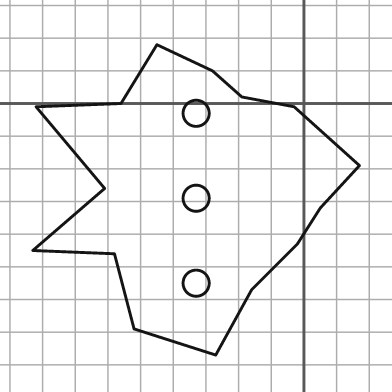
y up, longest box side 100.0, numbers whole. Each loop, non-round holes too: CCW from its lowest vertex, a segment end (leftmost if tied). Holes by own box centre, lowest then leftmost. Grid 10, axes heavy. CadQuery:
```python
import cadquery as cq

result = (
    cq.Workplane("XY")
    .moveTo(-27.0, -77.0)
    .lineTo(-16.0, -57.0)
    .lineTo(-2.0, -43.0)
    .lineTo(5.0, -32.0)
    .lineTo(17.0, -19.0)
    .lineTo(-3.0, -1.0)
    .lineTo(-19.0, 2.0)
    .lineTo(-28.0, 10.0)
    .lineTo(-45.0, 18.0)
    .lineTo(-56.0, 0.0)
    .lineTo(-82.0, -1.0)
    .lineTo(-61.0, -26.0)
    .lineTo(-83.0, -45.0)
    .lineTo(-58.0, -46.0)
    .lineTo(-52.0, -69.0)
    .close()
    .moveTo(-33.0, -55.0)
    .circle(4.0)
    .moveTo(-33.0, -29.0)
    .circle(4.0)
    .moveTo(-33.0, -3.0)
    .circle(4.0)
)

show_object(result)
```